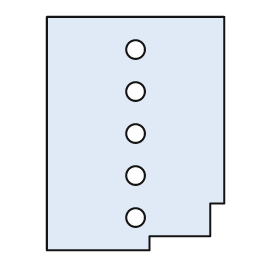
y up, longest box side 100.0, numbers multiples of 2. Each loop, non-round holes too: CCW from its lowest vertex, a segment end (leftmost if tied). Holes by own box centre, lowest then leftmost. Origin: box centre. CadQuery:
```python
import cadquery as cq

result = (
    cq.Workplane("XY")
    .moveTo(-38.0, -50.0)
    .lineTo(6.0, -50.0)
    .lineTo(6.0, -44.0)
    .lineTo(32.0, -44.0)
    .lineTo(32.0, -30.0)
    .lineTo(38.0, -30.0)
    .lineTo(38.0, 50.0)
    .lineTo(-38.0, 50.0)
    .close()
    .moveTo(0.0, -36.0)
    .circle(4.0)
    .moveTo(0.0, -18.0)
    .circle(4.0)
    .moveTo(0.0, 0.0)
    .circle(4.0)
    .moveTo(0.0, 18.0)
    .circle(4.0)
    .moveTo(0.0, 36.0)
    .circle(4.0)
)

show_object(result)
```